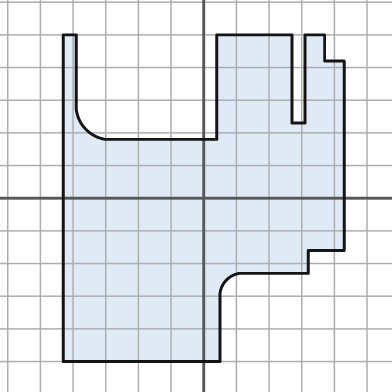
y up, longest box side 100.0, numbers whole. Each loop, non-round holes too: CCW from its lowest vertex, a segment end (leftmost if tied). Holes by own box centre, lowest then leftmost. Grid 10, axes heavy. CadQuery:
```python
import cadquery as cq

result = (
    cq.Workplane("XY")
    .moveTo(-43.0, -50.0)
    .lineTo(5.0, -50.0)
    .lineTo(5.0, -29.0)
    .threePointArc((7.0, -25.0), (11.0, -23.0))
    .lineTo(32.0, -23.0)
    .lineTo(32.0, -16.0)
    .lineTo(43.0, -16.0)
    .lineTo(43.0, 42.0)
    .lineTo(37.0, 42.0)
    .lineTo(37.0, 50.0)
    .lineTo(31.0, 50.0)
    .lineTo(31.0, 23.0)
    .lineTo(27.0, 23.0)
    .lineTo(27.0, 50.0)
    .lineTo(4.0, 50.0)
    .lineTo(4.0, 18.0)
    .lineTo(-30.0, 18.0)
    .threePointArc((-36.0, 21.0), (-39.0, 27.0))
    .lineTo(-39.0, 50.0)
    .lineTo(-43.0, 50.0)
    .close()
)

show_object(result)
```